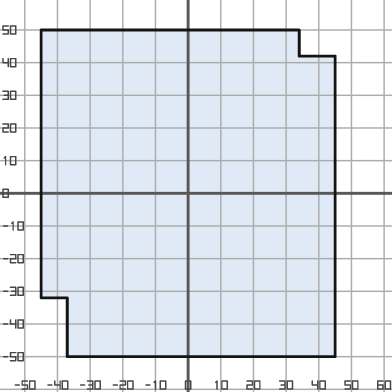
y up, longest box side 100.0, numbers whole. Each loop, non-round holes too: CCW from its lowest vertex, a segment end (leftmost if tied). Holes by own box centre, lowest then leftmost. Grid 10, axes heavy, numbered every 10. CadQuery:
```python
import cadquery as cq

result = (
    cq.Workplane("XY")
    .moveTo(-37.0, -50.0)
    .lineTo(45.0, -50.0)
    .lineTo(45.0, 42.0)
    .lineTo(34.0, 42.0)
    .lineTo(34.0, 50.0)
    .lineTo(-45.0, 50.0)
    .lineTo(-45.0, -32.0)
    .lineTo(-37.0, -32.0)
    .close()
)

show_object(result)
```